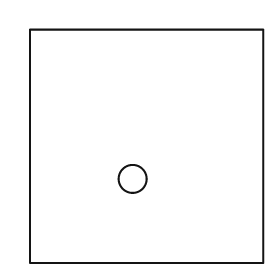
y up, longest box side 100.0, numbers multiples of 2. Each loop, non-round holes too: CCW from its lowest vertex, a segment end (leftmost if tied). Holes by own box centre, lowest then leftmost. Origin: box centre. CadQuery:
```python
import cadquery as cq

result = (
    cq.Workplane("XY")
    .moveTo(-50.0, -50.0)
    .lineTo(50.0, -50.0)
    .lineTo(50.0, 50.0)
    .lineTo(-50.0, 50.0)
    .close()
    .moveTo(-6.0, -14.0)
    .circle(6.0)
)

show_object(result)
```